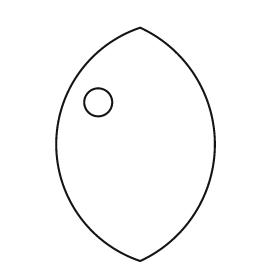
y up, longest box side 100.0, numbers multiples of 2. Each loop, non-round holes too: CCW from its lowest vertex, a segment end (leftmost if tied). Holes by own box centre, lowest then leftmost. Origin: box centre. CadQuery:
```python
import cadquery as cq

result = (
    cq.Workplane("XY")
    .moveTo(2.0, -50.0)
    .threePointArc((34.0, 0.0), (2.0, 50.0))
    .threePointArc((-34.0, 0.0), (2.0, -50.0))
    .close()
    .moveTo(-16.0, 18.0)
    .circle(6.0)
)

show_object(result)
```